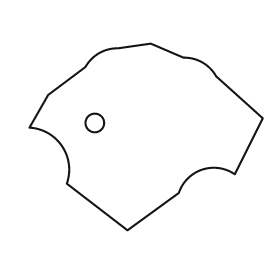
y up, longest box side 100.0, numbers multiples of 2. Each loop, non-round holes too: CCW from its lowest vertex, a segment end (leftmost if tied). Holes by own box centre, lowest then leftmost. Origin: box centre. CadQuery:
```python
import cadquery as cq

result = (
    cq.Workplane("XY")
    .moveTo(-8.0, -40.0)
    .lineTo(14.0, -24.0)
    .threePointArc((24.0, -14.0), (38.0, -16.0))
    .lineTo(50.0, 8.0)
    .lineTo(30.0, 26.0)
    .threePointArc((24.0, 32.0), (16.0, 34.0))
    .lineTo(2.0, 40.0)
    .lineTo(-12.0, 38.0)
    .threePointArc((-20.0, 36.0), (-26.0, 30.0))
    .lineTo(-42.0, 18.0)
    .lineTo(-50.0, 4.0)
    .threePointArc((-36.0, -4.0), (-34.0, -20.0))
    .close()
    .moveTo(-22.0, 6.0)
    .circle(4.0)
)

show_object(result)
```